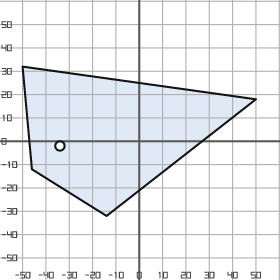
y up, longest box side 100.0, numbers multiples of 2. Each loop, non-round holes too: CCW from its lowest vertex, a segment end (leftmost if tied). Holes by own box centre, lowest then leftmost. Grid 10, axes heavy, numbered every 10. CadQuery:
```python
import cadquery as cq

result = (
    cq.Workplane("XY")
    .moveTo(-14.0, -32.0)
    .lineTo(50.0, 18.0)
    .lineTo(-50.0, 32.0)
    .lineTo(-46.0, -12.0)
    .close()
    .moveTo(-34.0, -2.0)
    .circle(2.0)
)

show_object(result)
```